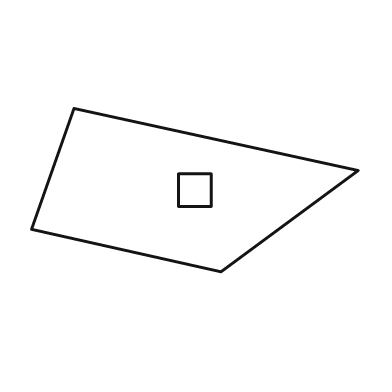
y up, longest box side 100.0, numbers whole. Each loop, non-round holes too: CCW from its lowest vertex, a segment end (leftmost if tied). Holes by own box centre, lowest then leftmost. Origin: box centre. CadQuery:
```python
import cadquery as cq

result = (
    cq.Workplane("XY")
    .moveTo(8.0, -25.0)
    .lineTo(50.0, 6.0)
    .lineTo(-37.0, 25.0)
    .lineTo(-50.0, -12.0)
    .close()
    .moveTo(-5.0, -5.0)
    .lineTo(5.0, -5.0)
    .lineTo(5.0, 5.0)
    .lineTo(-5.0, 5.0)
    .close()
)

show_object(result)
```